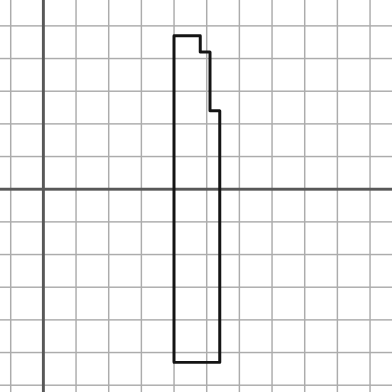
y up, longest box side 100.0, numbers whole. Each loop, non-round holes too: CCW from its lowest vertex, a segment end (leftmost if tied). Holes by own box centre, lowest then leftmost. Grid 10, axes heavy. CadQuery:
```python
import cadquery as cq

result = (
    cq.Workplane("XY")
    .moveTo(40.0, -53.0)
    .lineTo(54.0, -53.0)
    .lineTo(54.0, 24.0)
    .lineTo(51.0, 24.0)
    .lineTo(51.0, 42.0)
    .lineTo(48.0, 42.0)
    .lineTo(48.0, 47.0)
    .lineTo(40.0, 47.0)
    .close()
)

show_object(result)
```